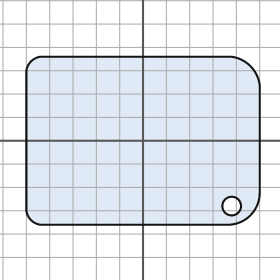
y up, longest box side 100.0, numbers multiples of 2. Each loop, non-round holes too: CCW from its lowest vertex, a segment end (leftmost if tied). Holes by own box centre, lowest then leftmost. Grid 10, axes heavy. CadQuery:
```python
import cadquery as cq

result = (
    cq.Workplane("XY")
    .moveTo(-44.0, -36.0)
    .lineTo(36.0, -36.0)
    .threePointArc((46.0, -32.0), (50.0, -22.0))
    .lineTo(50.0, 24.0)
    .threePointArc((46.0, 32.0), (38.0, 36.0))
    .lineTo(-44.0, 36.0)
    .threePointArc((-48.0, 34.0), (-50.0, 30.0))
    .lineTo(-50.0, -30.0)
    .threePointArc((-48.0, -34.0), (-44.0, -36.0))
    .close()
    .moveTo(38.0, -28.0)
    .circle(4.0)
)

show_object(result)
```